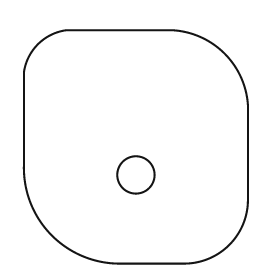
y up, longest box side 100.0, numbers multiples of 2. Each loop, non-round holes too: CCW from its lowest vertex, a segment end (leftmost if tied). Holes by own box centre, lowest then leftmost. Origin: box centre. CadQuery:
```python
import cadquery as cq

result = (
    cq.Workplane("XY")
    .moveTo(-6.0, -50.0)
    .lineTo(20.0, -50.0)
    .threePointArc((40.0, -42.0), (48.0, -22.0))
    .lineTo(48.0, 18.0)
    .threePointArc((38.0, 40.0), (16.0, 50.0))
    .lineTo(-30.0, 50.0)
    .threePointArc((-42.0, 44.0), (-48.0, 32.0))
    .lineTo(-48.0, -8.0)
    .threePointArc((-36.0, -38.0), (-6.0, -50.0))
    .close()
    .moveTo(0.0, -12.0)
    .circle(8.0)
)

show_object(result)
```